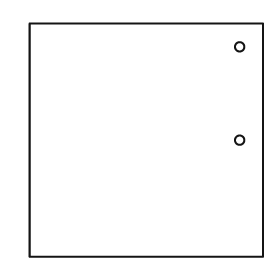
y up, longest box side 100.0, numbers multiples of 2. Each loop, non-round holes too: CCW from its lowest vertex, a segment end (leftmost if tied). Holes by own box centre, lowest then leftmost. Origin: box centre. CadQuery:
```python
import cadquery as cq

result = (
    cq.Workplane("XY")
    .moveTo(-50.0, -50.0)
    .lineTo(50.0, -50.0)
    .lineTo(50.0, 50.0)
    .lineTo(-50.0, 50.0)
    .close()
    .moveTo(40.0, 0.0)
    .circle(2.0)
    .moveTo(40.0, 40.0)
    .circle(2.0)
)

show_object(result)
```